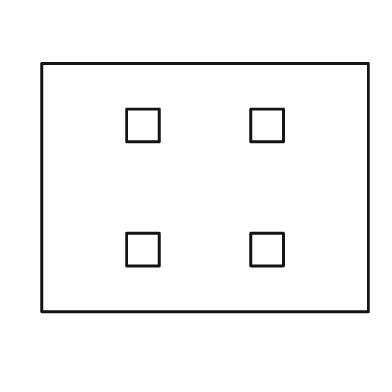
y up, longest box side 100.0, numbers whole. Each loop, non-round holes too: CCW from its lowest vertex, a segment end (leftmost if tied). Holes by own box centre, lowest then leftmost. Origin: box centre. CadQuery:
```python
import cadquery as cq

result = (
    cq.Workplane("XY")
    .moveTo(-50.0, -38.0)
    .lineTo(50.0, -38.0)
    .lineTo(50.0, 38.0)
    .lineTo(-50.0, 38.0)
    .close()
    .moveTo(-24.0, -24.0)
    .lineTo(-14.0, -24.0)
    .lineTo(-14.0, -14.0)
    .lineTo(-24.0, -14.0)
    .close()
    .moveTo(14.0, -24.0)
    .lineTo(24.0, -24.0)
    .lineTo(24.0, -14.0)
    .lineTo(14.0, -14.0)
    .close()
    .moveTo(-24.0, 14.0)
    .lineTo(-14.0, 14.0)
    .lineTo(-14.0, 24.0)
    .lineTo(-24.0, 24.0)
    .close()
    .moveTo(14.0, 14.0)
    .lineTo(24.0, 14.0)
    .lineTo(24.0, 24.0)
    .lineTo(14.0, 24.0)
    .close()
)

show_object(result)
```